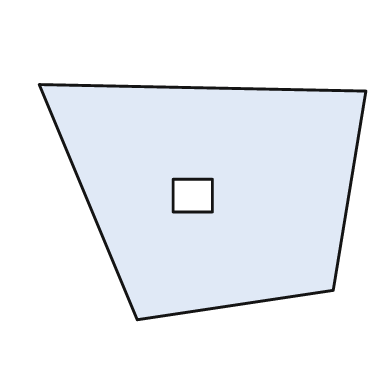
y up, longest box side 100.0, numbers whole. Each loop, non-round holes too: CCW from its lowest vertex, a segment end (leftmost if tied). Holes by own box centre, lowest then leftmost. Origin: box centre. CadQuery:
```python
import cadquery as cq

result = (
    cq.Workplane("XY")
    .moveTo(-20.0, -36.0)
    .lineTo(40.0, -27.0)
    .lineTo(50.0, 34.0)
    .lineTo(-50.0, 36.0)
    .close()
    .moveTo(-9.0, -3.0)
    .lineTo(3.0, -3.0)
    .lineTo(3.0, 7.0)
    .lineTo(-9.0, 7.0)
    .close()
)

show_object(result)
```